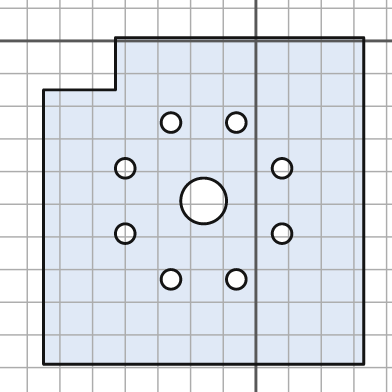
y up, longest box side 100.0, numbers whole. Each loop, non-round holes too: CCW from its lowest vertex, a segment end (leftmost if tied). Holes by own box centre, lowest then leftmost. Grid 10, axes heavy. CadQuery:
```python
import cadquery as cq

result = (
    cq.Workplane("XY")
    .moveTo(-65.0, -99.0)
    .lineTo(33.0, -99.0)
    .lineTo(33.0, 1.0)
    .lineTo(-43.0, 1.0)
    .lineTo(-43.0, -15.0)
    .lineTo(-65.0, -15.0)
    .close()
    .moveTo(-26.0, -73.0)
    .circle(3.0)
    .moveTo(-6.0, -73.0)
    .circle(3.0)
    .moveTo(-40.0, -59.0)
    .circle(3.0)
    .moveTo(8.0, -59.0)
    .circle(3.0)
    .moveTo(-16.0, -49.0)
    .circle(7.0)
    .moveTo(-40.0, -39.0)
    .circle(3.0)
    .moveTo(8.0, -39.0)
    .circle(3.0)
    .moveTo(-26.0, -25.0)
    .circle(3.0)
    .moveTo(-6.0, -25.0)
    .circle(3.0)
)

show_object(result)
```